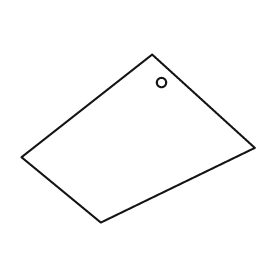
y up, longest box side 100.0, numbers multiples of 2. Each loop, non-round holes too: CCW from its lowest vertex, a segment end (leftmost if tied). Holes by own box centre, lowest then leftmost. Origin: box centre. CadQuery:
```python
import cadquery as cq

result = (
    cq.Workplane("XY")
    .moveTo(-16.0, -36.0)
    .lineTo(50.0, -4.0)
    .lineTo(6.0, 36.0)
    .lineTo(-50.0, -8.0)
    .close()
    .moveTo(10.0, 24.0)
    .circle(2.0)
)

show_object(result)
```